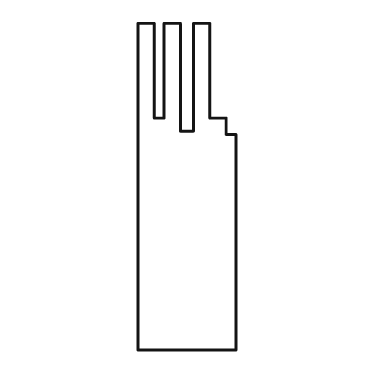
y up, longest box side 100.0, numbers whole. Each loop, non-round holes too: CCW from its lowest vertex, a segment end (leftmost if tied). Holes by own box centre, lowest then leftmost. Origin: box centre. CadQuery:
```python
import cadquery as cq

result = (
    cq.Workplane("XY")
    .moveTo(-15.0, -50.0)
    .lineTo(15.0, -50.0)
    .lineTo(15.0, 16.0)
    .lineTo(12.0, 16.0)
    .lineTo(12.0, 21.0)
    .lineTo(7.0, 21.0)
    .lineTo(7.0, 50.0)
    .lineTo(2.0, 50.0)
    .lineTo(2.0, 17.0)
    .lineTo(-2.0, 17.0)
    .lineTo(-2.0, 50.0)
    .lineTo(-7.0, 50.0)
    .lineTo(-7.0, 21.0)
    .lineTo(-10.0, 21.0)
    .lineTo(-10.0, 50.0)
    .lineTo(-15.0, 50.0)
    .close()
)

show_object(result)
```